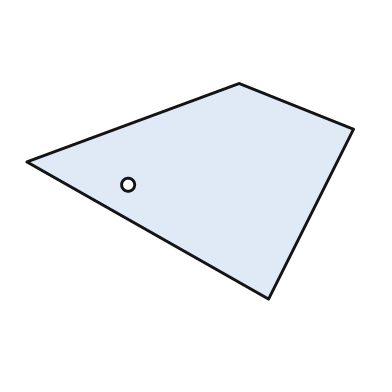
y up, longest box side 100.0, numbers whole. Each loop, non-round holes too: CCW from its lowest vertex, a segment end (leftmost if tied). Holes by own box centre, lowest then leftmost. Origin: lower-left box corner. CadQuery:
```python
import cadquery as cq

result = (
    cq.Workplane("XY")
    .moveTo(74.0, 0.0)
    .lineTo(100.0, 52.0)
    .lineTo(65.0, 66.0)
    .lineTo(0.0, 42.0)
    .close()
    .moveTo(31.0, 35.0)
    .circle(2.0)
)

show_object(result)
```